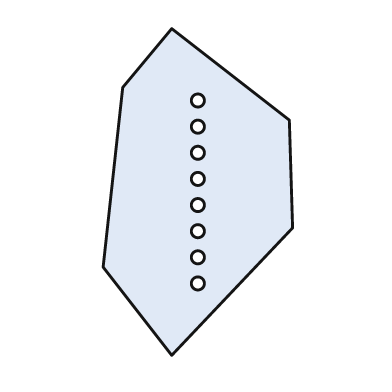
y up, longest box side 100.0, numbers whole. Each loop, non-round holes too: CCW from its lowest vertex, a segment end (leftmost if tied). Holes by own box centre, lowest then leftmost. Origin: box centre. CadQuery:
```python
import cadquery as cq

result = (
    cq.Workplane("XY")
    .moveTo(-8.0, -50.0)
    .lineTo(29.0, -11.0)
    .lineTo(28.0, 22.0)
    .lineTo(-8.0, 50.0)
    .lineTo(-23.0, 32.0)
    .lineTo(-29.0, -23.0)
    .close()
    .moveTo(0.0, -28.0)
    .circle(2.0)
    .moveTo(0.0, -20.0)
    .circle(2.0)
    .moveTo(0.0, -12.0)
    .circle(2.0)
    .moveTo(0.0, -4.0)
    .circle(2.0)
    .moveTo(0.0, 4.0)
    .circle(2.0)
    .moveTo(0.0, 12.0)
    .circle(2.0)
    .moveTo(0.0, 20.0)
    .circle(2.0)
    .moveTo(0.0, 28.0)
    .circle(2.0)
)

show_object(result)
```